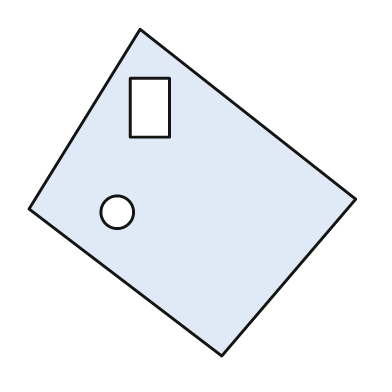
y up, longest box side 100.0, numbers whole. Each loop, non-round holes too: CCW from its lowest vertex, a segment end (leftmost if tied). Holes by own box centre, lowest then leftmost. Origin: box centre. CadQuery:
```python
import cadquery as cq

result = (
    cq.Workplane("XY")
    .moveTo(9.0, -50.0)
    .lineTo(50.0, -2.0)
    .lineTo(-16.0, 50.0)
    .lineTo(-50.0, -5.0)
    .close()
    .moveTo(-23.0, -6.0)
    .circle(5.0)
    .moveTo(-19.0, 17.0)
    .lineTo(-7.0, 17.0)
    .lineTo(-7.0, 35.0)
    .lineTo(-19.0, 35.0)
    .close()
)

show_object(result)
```